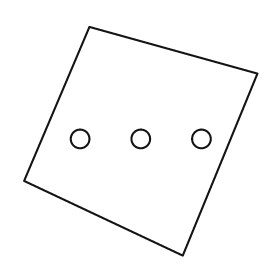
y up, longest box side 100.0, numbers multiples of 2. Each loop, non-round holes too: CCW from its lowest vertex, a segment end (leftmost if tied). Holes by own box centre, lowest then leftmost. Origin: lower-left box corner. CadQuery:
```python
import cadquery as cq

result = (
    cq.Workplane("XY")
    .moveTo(68.0, 0.0)
    .lineTo(100.0, 78.0)
    .lineTo(28.0, 98.0)
    .lineTo(0.0, 32.0)
    .close()
    .moveTo(24.0, 50.0)
    .circle(4.0)
    .moveTo(50.0, 50.0)
    .circle(4.0)
    .moveTo(76.0, 50.0)
    .circle(4.0)
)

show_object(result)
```